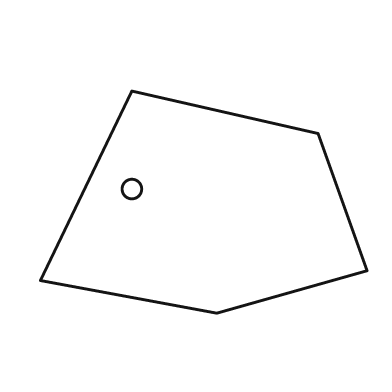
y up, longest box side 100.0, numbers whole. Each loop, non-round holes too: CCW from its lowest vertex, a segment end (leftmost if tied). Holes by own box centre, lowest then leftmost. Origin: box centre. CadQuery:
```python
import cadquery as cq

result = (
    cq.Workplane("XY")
    .moveTo(4.0, -34.0)
    .lineTo(50.0, -21.0)
    .lineTo(35.0, 21.0)
    .lineTo(-22.0, 34.0)
    .lineTo(-50.0, -24.0)
    .close()
    .moveTo(-22.0, 4.0)
    .circle(3.0)
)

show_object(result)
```